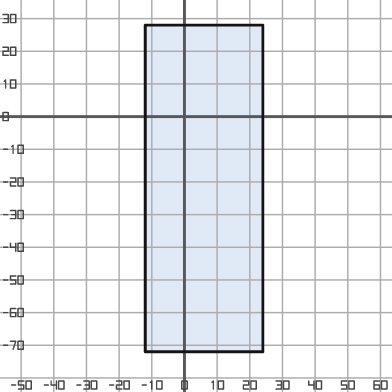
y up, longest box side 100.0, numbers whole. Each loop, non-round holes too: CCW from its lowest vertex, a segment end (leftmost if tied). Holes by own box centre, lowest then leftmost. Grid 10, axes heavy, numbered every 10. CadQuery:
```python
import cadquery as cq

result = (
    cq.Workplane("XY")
    .moveTo(-12.0, -72.0)
    .lineTo(24.0, -72.0)
    .lineTo(24.0, 28.0)
    .lineTo(-12.0, 28.0)
    .close()
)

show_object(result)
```